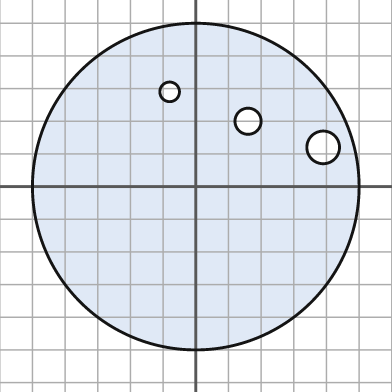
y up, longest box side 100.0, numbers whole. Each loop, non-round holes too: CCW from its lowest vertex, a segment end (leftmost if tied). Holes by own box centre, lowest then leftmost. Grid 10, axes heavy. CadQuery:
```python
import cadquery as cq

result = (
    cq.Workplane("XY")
    .moveTo(0.0, 0.0)
    .circle(50.0)
    .moveTo(39.0, 12.0)
    .circle(5.0)
    .moveTo(16.0, 20.0)
    .circle(4.0)
    .moveTo(-8.0, 29.0)
    .circle(3.0)
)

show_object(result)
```